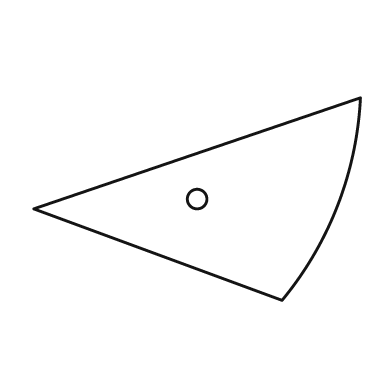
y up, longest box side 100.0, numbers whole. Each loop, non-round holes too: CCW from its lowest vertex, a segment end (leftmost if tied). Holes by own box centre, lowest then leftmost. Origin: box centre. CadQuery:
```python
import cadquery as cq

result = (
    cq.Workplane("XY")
    .moveTo(26.0, -31.0)
    .threePointArc((43.0, -2.0), (50.0, 31.0))
    .lineTo(-50.0, -3.0)
    .close()
    .moveTo(0.0, 0.0)
    .circle(3.0)
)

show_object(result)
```